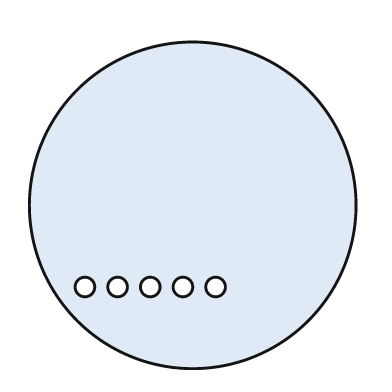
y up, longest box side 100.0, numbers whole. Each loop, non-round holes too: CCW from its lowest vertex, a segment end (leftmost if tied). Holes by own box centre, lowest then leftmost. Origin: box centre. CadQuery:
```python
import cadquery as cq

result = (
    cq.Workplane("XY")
    .moveTo(0.0, 0.0)
    .circle(50.0)
    .moveTo(-33.0, -25.0)
    .circle(3.0)
    .moveTo(-23.0, -25.0)
    .circle(3.0)
    .moveTo(-13.0, -25.0)
    .circle(3.0)
    .moveTo(-3.0, -25.0)
    .circle(3.0)
    .moveTo(7.0, -25.0)
    .circle(3.0)
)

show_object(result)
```